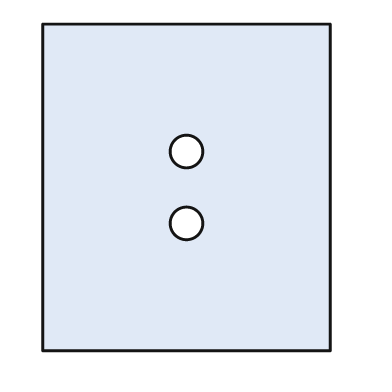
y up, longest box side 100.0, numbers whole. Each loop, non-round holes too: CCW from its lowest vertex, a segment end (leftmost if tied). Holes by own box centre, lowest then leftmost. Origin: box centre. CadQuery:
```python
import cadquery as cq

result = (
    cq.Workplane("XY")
    .moveTo(-44.0, -50.0)
    .lineTo(44.0, -50.0)
    .lineTo(44.0, 50.0)
    .lineTo(-44.0, 50.0)
    .close()
    .moveTo(0.0, -11.0)
    .circle(5.0)
    .moveTo(0.0, 11.0)
    .circle(5.0)
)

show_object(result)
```